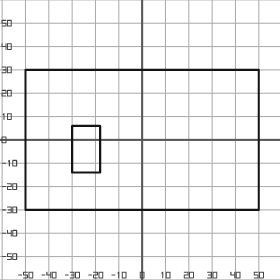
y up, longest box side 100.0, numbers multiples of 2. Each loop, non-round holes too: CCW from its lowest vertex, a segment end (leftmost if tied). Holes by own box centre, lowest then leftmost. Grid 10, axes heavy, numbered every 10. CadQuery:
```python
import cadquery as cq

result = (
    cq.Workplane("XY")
    .moveTo(-50.0, -30.0)
    .lineTo(50.0, -30.0)
    .lineTo(50.0, 30.0)
    .lineTo(-50.0, 30.0)
    .close()
    .moveTo(-30.0, -14.0)
    .lineTo(-18.0, -14.0)
    .lineTo(-18.0, 6.0)
    .lineTo(-30.0, 6.0)
    .close()
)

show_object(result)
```